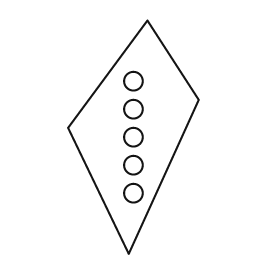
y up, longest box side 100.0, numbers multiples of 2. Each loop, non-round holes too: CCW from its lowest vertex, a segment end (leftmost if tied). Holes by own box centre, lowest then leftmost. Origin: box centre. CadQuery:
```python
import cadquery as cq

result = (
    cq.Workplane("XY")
    .moveTo(-2.0, -50.0)
    .lineTo(28.0, 16.0)
    .lineTo(6.0, 50.0)
    .lineTo(-28.0, 4.0)
    .close()
    .moveTo(0.0, -24.0)
    .circle(4.0)
    .moveTo(0.0, -12.0)
    .circle(4.0)
    .moveTo(0.0, 0.0)
    .circle(4.0)
    .moveTo(0.0, 12.0)
    .circle(4.0)
    .moveTo(0.0, 24.0)
    .circle(4.0)
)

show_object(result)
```